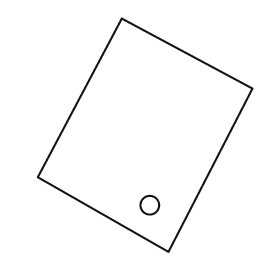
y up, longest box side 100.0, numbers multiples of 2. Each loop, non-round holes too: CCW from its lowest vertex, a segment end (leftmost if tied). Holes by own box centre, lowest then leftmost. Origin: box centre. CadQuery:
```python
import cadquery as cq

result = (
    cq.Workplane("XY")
    .moveTo(10.0, -50.0)
    .lineTo(46.0, 20.0)
    .lineTo(-10.0, 50.0)
    .lineTo(-46.0, -18.0)
    .close()
    .moveTo(2.0, -30.0)
    .circle(4.0)
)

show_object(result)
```